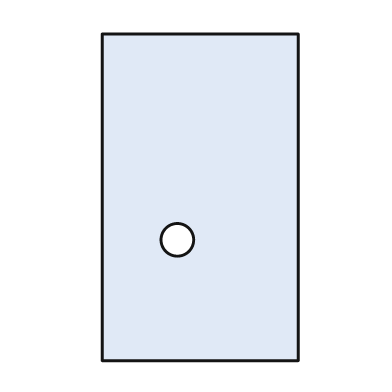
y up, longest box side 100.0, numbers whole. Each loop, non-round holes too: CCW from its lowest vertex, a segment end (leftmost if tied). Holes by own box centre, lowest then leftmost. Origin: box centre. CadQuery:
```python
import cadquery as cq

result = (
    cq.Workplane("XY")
    .moveTo(-30.0, -50.0)
    .lineTo(30.0, -50.0)
    .lineTo(30.0, 50.0)
    .lineTo(-30.0, 50.0)
    .close()
    .moveTo(-7.0, -13.0)
    .circle(5.0)
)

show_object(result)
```